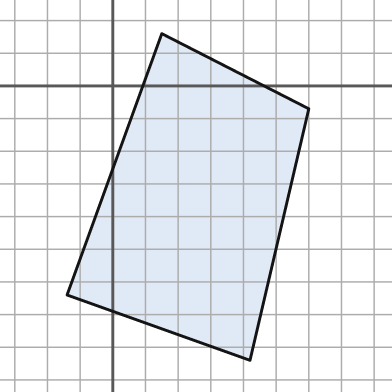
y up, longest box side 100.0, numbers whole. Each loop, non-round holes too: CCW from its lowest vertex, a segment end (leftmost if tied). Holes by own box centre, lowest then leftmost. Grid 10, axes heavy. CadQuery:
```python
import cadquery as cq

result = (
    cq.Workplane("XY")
    .moveTo(42.0, -84.0)
    .lineTo(60.0, -7.0)
    .lineTo(15.0, 16.0)
    .lineTo(-14.0, -64.0)
    .close()
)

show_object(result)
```